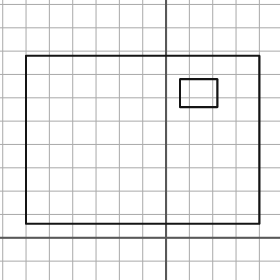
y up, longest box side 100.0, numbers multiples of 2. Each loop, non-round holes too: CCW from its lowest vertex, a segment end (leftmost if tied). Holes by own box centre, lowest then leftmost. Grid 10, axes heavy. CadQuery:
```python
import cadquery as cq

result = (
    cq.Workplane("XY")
    .moveTo(-60.0, 6.0)
    .lineTo(40.0, 6.0)
    .lineTo(40.0, 78.0)
    .lineTo(-60.0, 78.0)
    .close()
    .moveTo(6.0, 56.0)
    .lineTo(22.0, 56.0)
    .lineTo(22.0, 68.0)
    .lineTo(6.0, 68.0)
    .close()
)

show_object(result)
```